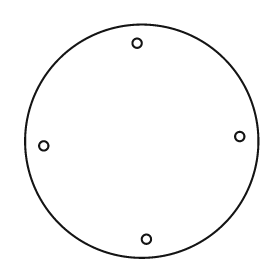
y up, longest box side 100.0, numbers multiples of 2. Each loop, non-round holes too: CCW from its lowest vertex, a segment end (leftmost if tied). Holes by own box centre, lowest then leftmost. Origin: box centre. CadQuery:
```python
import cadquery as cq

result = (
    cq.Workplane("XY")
    .moveTo(0.0, 0.0)
    .circle(50.0)
    .moveTo(2.0, -42.0)
    .circle(2.0)
    .moveTo(-42.0, -2.0)
    .circle(2.0)
    .moveTo(42.0, 2.0)
    .circle(2.0)
    .moveTo(-2.0, 42.0)
    .circle(2.0)
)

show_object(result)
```